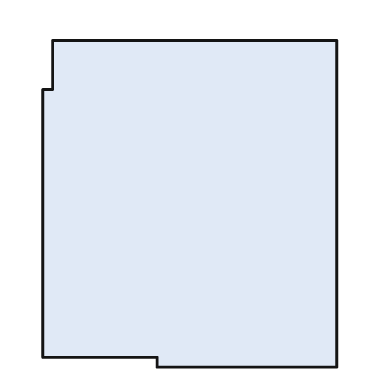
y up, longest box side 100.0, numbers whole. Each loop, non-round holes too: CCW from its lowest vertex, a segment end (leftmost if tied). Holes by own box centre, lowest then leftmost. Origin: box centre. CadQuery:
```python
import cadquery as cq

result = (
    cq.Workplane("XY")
    .moveTo(-10.0, -50.0)
    .lineTo(45.0, -50.0)
    .lineTo(45.0, 50.0)
    .lineTo(-42.0, 50.0)
    .lineTo(-42.0, 35.0)
    .lineTo(-45.0, 35.0)
    .lineTo(-45.0, -47.0)
    .lineTo(-10.0, -47.0)
    .close()
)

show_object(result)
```